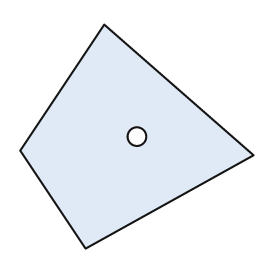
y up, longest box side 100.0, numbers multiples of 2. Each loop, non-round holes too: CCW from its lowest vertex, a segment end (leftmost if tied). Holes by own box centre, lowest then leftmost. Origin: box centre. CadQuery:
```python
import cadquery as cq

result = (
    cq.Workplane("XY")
    .moveTo(-22.0, -48.0)
    .lineTo(50.0, -8.0)
    .lineTo(-14.0, 48.0)
    .lineTo(-50.0, -6.0)
    .close()
    .moveTo(0.0, 0.0)
    .circle(4.0)
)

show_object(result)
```